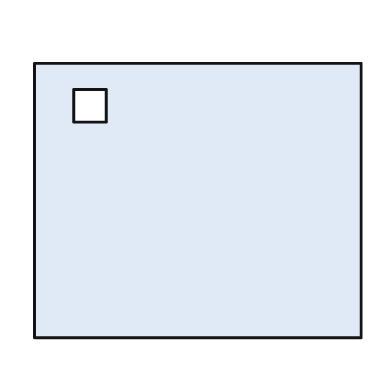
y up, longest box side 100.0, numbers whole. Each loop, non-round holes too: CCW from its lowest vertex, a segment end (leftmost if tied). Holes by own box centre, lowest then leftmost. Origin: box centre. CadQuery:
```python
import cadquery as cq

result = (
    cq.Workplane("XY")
    .moveTo(-50.0, -42.0)
    .lineTo(50.0, -42.0)
    .lineTo(50.0, 42.0)
    .lineTo(-50.0, 42.0)
    .close()
    .moveTo(-38.0, 24.0)
    .lineTo(-28.0, 24.0)
    .lineTo(-28.0, 34.0)
    .lineTo(-38.0, 34.0)
    .close()
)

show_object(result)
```